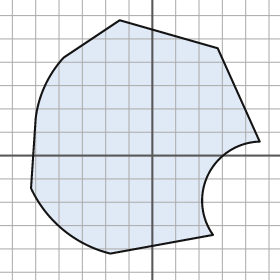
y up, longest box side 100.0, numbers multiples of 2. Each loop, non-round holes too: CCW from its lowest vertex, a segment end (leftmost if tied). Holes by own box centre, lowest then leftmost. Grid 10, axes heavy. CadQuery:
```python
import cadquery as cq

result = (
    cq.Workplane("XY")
    .moveTo(-18.0, -42.0)
    .lineTo(26.0, -34.0)
    .threePointArc((24.0, -8.0), (46.0, 6.0))
    .lineTo(28.0, 46.0)
    .lineTo(-14.0, 58.0)
    .lineTo(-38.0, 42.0)
    .threePointArc((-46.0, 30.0), (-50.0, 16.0))
    .lineTo(-52.0, -14.0)
    .threePointArc((-38.0, -32.0), (-18.0, -42.0))
    .close()
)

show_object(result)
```